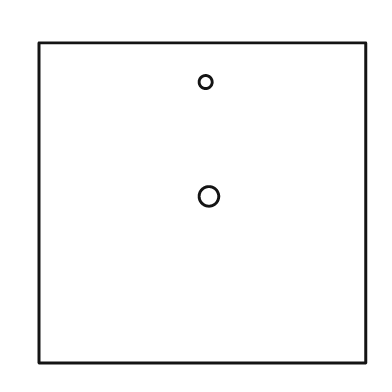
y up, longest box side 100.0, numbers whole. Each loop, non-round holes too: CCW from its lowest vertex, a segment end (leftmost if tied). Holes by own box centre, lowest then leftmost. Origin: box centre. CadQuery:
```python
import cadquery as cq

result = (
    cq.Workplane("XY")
    .moveTo(-50.0, -49.0)
    .lineTo(50.0, -49.0)
    .lineTo(50.0, 49.0)
    .lineTo(-50.0, 49.0)
    .close()
    .moveTo(2.0, 2.0)
    .circle(3.0)
    .moveTo(1.0, 37.0)
    .circle(2.0)
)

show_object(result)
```